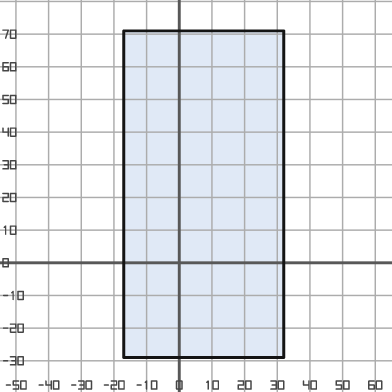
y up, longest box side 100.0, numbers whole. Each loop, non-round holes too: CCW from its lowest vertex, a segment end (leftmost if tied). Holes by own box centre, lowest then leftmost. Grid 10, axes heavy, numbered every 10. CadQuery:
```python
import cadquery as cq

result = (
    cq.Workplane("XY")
    .moveTo(-17.0, -29.0)
    .lineTo(32.0, -29.0)
    .lineTo(32.0, 71.0)
    .lineTo(-17.0, 71.0)
    .close()
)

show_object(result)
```